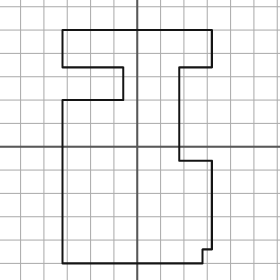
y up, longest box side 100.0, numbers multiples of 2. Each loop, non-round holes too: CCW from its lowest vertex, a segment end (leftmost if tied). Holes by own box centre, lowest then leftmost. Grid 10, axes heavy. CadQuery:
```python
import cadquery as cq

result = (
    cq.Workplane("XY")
    .moveTo(-32.0, -50.0)
    .lineTo(28.0, -50.0)
    .lineTo(28.0, -44.0)
    .lineTo(32.0, -44.0)
    .lineTo(32.0, -6.0)
    .lineTo(18.0, -6.0)
    .lineTo(18.0, 34.0)
    .lineTo(32.0, 34.0)
    .lineTo(32.0, 50.0)
    .lineTo(-32.0, 50.0)
    .lineTo(-32.0, 34.0)
    .lineTo(-6.0, 34.0)
    .lineTo(-6.0, 20.0)
    .lineTo(-32.0, 20.0)
    .close()
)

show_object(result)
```